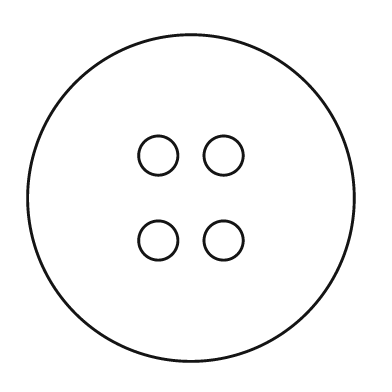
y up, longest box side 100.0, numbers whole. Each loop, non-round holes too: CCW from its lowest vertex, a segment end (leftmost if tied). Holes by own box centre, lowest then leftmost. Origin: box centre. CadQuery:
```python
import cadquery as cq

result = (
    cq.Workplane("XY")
    .moveTo(0.0, 0.0)
    .circle(50.0)
    .moveTo(-10.0, -13.0)
    .circle(6.0)
    .moveTo(10.0, -13.0)
    .circle(6.0)
    .moveTo(-10.0, 13.0)
    .circle(6.0)
    .moveTo(10.0, 13.0)
    .circle(6.0)
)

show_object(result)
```